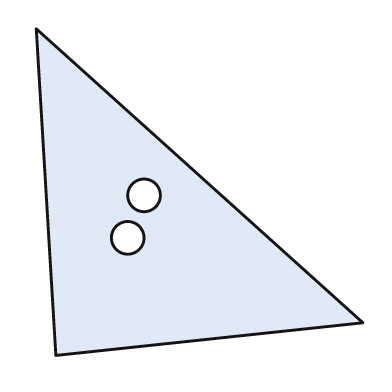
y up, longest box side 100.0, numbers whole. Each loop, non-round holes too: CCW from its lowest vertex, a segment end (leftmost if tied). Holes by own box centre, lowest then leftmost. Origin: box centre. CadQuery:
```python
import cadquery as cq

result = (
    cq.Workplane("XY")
    .moveTo(-44.0, -50.0)
    .lineTo(50.0, -40.0)
    .lineTo(-50.0, 50.0)
    .close()
    .moveTo(-22.0, -14.0)
    .circle(5.0)
    .moveTo(-17.0, -1.0)
    .circle(5.0)
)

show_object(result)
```